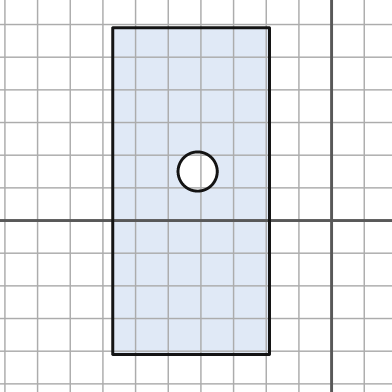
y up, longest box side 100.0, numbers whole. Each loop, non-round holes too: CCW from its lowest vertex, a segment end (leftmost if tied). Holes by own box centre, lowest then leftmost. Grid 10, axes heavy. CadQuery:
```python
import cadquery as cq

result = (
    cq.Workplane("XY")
    .moveTo(-67.0, -41.0)
    .lineTo(-19.0, -41.0)
    .lineTo(-19.0, 59.0)
    .lineTo(-67.0, 59.0)
    .close()
    .moveTo(-41.0, 15.0)
    .circle(6.0)
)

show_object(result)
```